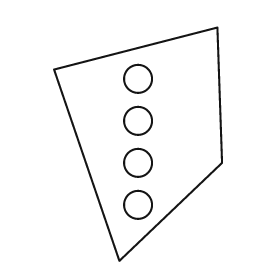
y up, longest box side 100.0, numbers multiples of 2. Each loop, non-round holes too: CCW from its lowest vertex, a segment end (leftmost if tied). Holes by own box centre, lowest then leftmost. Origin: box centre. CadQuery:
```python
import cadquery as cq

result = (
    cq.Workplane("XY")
    .moveTo(-8.0, -50.0)
    .lineTo(36.0, -8.0)
    .lineTo(34.0, 50.0)
    .lineTo(-36.0, 32.0)
    .close()
    .moveTo(0.0, -26.0)
    .circle(6.0)
    .moveTo(0.0, -8.0)
    .circle(6.0)
    .moveTo(0.0, 10.0)
    .circle(6.0)
    .moveTo(0.0, 28.0)
    .circle(6.0)
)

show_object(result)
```